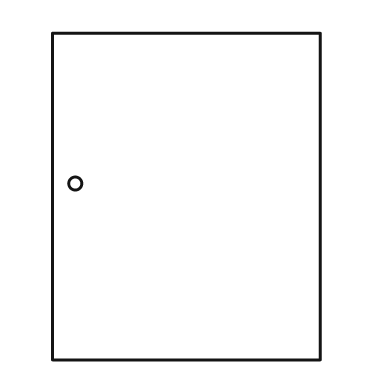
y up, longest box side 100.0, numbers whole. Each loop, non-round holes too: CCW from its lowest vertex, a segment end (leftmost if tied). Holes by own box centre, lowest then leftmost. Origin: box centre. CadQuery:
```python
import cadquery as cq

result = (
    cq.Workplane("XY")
    .moveTo(-41.0, -50.0)
    .lineTo(41.0, -50.0)
    .lineTo(41.0, 50.0)
    .lineTo(-41.0, 50.0)
    .close()
    .moveTo(-34.0, 4.0)
    .circle(2.0)
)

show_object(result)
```